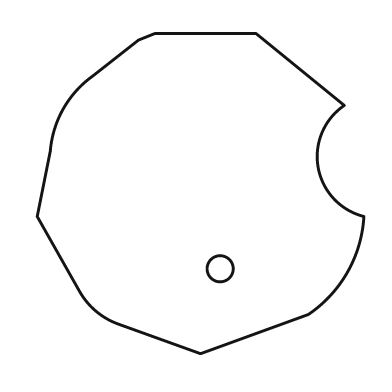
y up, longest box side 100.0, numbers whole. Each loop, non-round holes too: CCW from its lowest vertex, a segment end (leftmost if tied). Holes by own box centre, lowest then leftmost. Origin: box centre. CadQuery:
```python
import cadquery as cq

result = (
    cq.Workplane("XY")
    .moveTo(0.0, -49.0)
    .lineTo(33.0, -37.0)
    .threePointArc((45.0, -24.0), (50.0, -7.0))
    .threePointArc((36.0, 8.0), (44.0, 27.0))
    .lineTo(17.0, 49.0)
    .lineTo(-14.0, 49.0)
    .lineTo(-19.0, 47.0)
    .lineTo(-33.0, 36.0)
    .threePointArc((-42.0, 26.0), (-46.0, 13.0))
    .lineTo(-50.0, -7.0)
    .lineTo(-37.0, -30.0)
    .threePointArc((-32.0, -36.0), (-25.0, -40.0))
    .close()
    .moveTo(6.0, -23.0)
    .circle(4.0)
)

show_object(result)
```